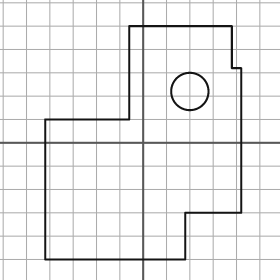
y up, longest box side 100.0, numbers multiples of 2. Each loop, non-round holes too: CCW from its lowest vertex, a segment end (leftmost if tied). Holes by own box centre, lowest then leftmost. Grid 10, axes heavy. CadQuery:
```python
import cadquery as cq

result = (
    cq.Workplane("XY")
    .moveTo(-42.0, -50.0)
    .lineTo(18.0, -50.0)
    .lineTo(18.0, -30.0)
    .lineTo(42.0, -30.0)
    .lineTo(42.0, 32.0)
    .lineTo(38.0, 32.0)
    .lineTo(38.0, 50.0)
    .lineTo(-6.0, 50.0)
    .lineTo(-6.0, 10.0)
    .lineTo(-42.0, 10.0)
    .close()
    .moveTo(20.0, 22.0)
    .circle(8.0)
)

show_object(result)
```